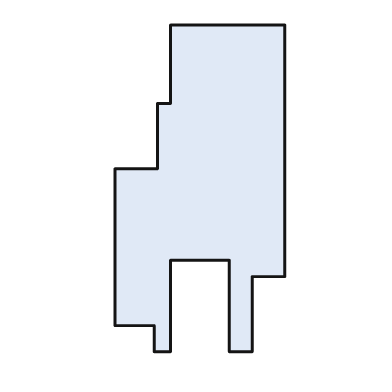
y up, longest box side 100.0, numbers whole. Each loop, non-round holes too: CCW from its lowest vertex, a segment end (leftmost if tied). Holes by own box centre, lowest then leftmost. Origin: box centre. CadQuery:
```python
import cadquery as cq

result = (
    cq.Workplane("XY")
    .moveTo(-14.0, -50.0)
    .lineTo(-9.0, -50.0)
    .lineTo(-9.0, -22.0)
    .lineTo(9.0, -22.0)
    .lineTo(9.0, -50.0)
    .lineTo(16.0, -50.0)
    .lineTo(16.0, -27.0)
    .lineTo(26.0, -27.0)
    .lineTo(26.0, 50.0)
    .lineTo(-9.0, 50.0)
    .lineTo(-9.0, 26.0)
    .lineTo(-13.0, 26.0)
    .lineTo(-13.0, 6.0)
    .lineTo(-26.0, 6.0)
    .lineTo(-26.0, -42.0)
    .lineTo(-14.0, -42.0)
    .close()
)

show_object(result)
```